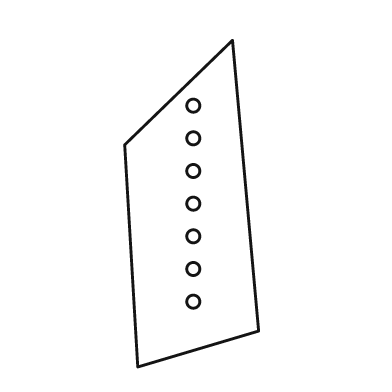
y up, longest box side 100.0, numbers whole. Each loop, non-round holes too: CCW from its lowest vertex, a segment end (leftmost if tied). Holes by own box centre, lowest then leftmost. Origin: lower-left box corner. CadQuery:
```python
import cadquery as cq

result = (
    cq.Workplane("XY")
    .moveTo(4.0, 0.0)
    .lineTo(41.0, 11.0)
    .lineTo(33.0, 100.0)
    .lineTo(0.0, 68.0)
    .close()
    .moveTo(21.0, 20.0)
    .circle(2.0)
    .moveTo(21.0, 30.0)
    .circle(2.0)
    .moveTo(21.0, 40.0)
    .circle(2.0)
    .moveTo(21.0, 50.0)
    .circle(2.0)
    .moveTo(21.0, 60.0)
    .circle(2.0)
    .moveTo(21.0, 70.0)
    .circle(2.0)
    .moveTo(21.0, 80.0)
    .circle(2.0)
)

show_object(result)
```